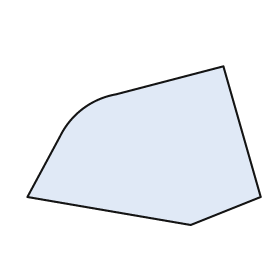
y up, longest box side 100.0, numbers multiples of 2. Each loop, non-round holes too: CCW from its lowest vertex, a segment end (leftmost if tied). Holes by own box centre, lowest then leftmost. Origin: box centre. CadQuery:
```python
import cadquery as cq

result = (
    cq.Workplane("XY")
    .moveTo(20.0, -34.0)
    .lineTo(50.0, -22.0)
    .lineTo(34.0, 34.0)
    .lineTo(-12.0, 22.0)
    .threePointArc((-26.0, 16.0), (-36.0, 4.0))
    .lineTo(-50.0, -22.0)
    .close()
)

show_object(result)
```